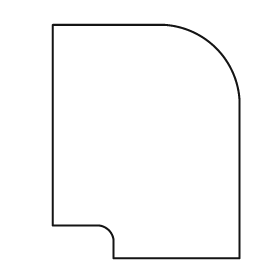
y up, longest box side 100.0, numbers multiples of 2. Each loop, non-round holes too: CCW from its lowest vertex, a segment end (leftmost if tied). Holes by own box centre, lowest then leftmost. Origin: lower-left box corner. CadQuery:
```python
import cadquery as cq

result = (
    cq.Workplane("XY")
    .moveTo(26.0, 0.0)
    .lineTo(80.0, 0.0)
    .lineTo(80.0, 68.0)
    .threePointArc((70.0, 90.0), (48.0, 100.0))
    .lineTo(0.0, 100.0)
    .lineTo(0.0, 14.0)
    .lineTo(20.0, 14.0)
    .threePointArc((24.0, 12.0), (26.0, 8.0))
    .close()
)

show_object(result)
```